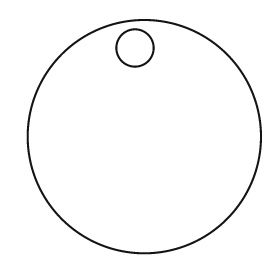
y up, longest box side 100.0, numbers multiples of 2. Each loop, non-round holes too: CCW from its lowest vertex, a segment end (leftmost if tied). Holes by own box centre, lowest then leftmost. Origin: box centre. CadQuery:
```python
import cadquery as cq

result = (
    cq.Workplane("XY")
    .moveTo(0.0, 0.0)
    .circle(50.0)
    .moveTo(-4.0, 38.0)
    .circle(8.0)
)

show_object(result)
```